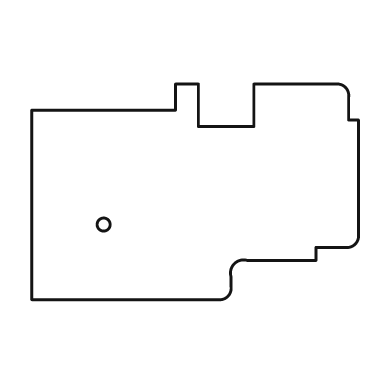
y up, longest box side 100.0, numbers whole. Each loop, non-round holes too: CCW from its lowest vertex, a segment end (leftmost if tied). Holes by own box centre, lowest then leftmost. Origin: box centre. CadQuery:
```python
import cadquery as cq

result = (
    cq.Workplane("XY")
    .moveTo(-50.0, -33.0)
    .lineTo(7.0, -33.0)
    .threePointArc((10.0, -32.0), (11.0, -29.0))
    .lineTo(11.0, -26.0)
    .threePointArc((12.0, -22.0), (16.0, -21.0))
    .lineTo(37.0, -21.0)
    .lineTo(37.0, -17.0)
    .lineTo(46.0, -17.0)
    .threePointArc((49.0, -16.0), (50.0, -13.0))
    .lineTo(50.0, 22.0)
    .lineTo(47.0, 22.0)
    .lineTo(47.0, 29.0)
    .threePointArc((46.0, 32.0), (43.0, 33.0))
    .lineTo(18.0, 33.0)
    .lineTo(18.0, 20.0)
    .lineTo(1.0, 20.0)
    .lineTo(1.0, 33.0)
    .lineTo(-6.0, 33.0)
    .lineTo(-6.0, 25.0)
    .lineTo(-50.0, 25.0)
    .close()
    .moveTo(-28.0, -10.0)
    .circle(2.0)
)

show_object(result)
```